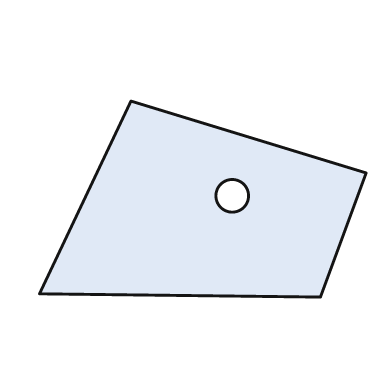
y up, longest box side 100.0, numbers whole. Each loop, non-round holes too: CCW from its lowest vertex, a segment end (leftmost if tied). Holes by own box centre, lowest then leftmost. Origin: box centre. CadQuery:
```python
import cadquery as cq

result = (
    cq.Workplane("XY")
    .moveTo(36.0, -30.0)
    .lineTo(50.0, 8.0)
    .lineTo(-22.0, 30.0)
    .lineTo(-50.0, -29.0)
    .close()
    .moveTo(9.0, 1.0)
    .circle(5.0)
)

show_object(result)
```